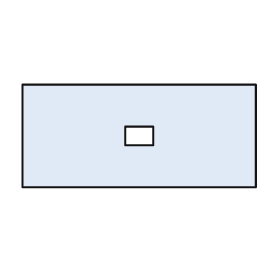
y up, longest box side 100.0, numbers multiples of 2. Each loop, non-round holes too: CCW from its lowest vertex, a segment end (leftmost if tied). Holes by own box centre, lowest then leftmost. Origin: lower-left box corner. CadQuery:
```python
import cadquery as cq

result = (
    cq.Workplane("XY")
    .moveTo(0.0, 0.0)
    .lineTo(100.0, 0.0)
    .lineTo(100.0, 44.0)
    .lineTo(0.0, 44.0)
    .close()
    .moveTo(44.0, 18.0)
    .lineTo(56.0, 18.0)
    .lineTo(56.0, 26.0)
    .lineTo(44.0, 26.0)
    .close()
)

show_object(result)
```